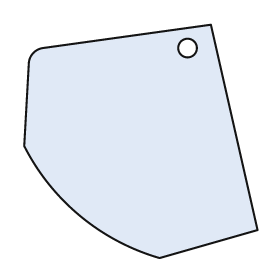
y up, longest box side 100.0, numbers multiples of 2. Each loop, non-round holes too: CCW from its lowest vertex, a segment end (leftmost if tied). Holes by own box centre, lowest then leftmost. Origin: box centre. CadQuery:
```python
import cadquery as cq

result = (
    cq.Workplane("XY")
    .moveTo(8.0, -50.0)
    .lineTo(50.0, -38.0)
    .lineTo(30.0, 50.0)
    .lineTo(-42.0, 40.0)
    .threePointArc((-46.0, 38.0), (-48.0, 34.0))
    .lineTo(-50.0, -2.0)
    .threePointArc((-26.0, -32.0), (8.0, -50.0))
    .close()
    .moveTo(20.0, 40.0)
    .circle(4.0)
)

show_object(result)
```